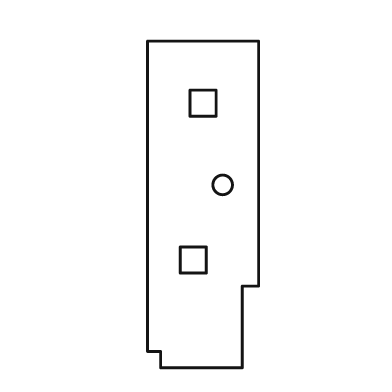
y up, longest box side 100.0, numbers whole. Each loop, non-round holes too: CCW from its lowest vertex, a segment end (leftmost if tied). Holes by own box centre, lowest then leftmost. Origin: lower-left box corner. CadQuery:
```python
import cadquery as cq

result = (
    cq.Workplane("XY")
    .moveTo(4.0, 0.0)
    .lineTo(29.0, 0.0)
    .lineTo(29.0, 25.0)
    .lineTo(34.0, 25.0)
    .lineTo(34.0, 100.0)
    .lineTo(0.0, 100.0)
    .lineTo(0.0, 5.0)
    .lineTo(4.0, 5.0)
    .close()
    .moveTo(10.0, 29.0)
    .lineTo(18.0, 29.0)
    .lineTo(18.0, 37.0)
    .lineTo(10.0, 37.0)
    .close()
    .moveTo(23.0, 56.0)
    .circle(3.0)
    .moveTo(13.0, 77.0)
    .lineTo(21.0, 77.0)
    .lineTo(21.0, 85.0)
    .lineTo(13.0, 85.0)
    .close()
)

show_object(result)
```